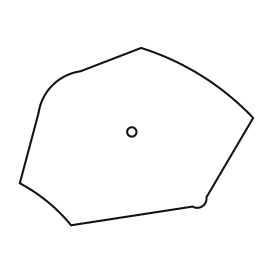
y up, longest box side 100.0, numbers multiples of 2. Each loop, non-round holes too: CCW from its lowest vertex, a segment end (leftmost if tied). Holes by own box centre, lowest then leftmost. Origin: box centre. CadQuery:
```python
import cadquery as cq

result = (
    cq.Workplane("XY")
    .moveTo(-28.0, -38.0)
    .lineTo(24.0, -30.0)
    .threePointArc((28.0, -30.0), (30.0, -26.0))
    .lineTo(50.0, 8.0)
    .threePointArc((28.0, 26.0), (2.0, 38.0))
    .lineTo(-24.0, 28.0)
    .threePointArc((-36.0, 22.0), (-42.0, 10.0))
    .lineTo(-50.0, -20.0)
    .threePointArc((-38.0, -28.0), (-28.0, -38.0))
    .close()
    .moveTo(-2.0, 2.0)
    .circle(2.0)
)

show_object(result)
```